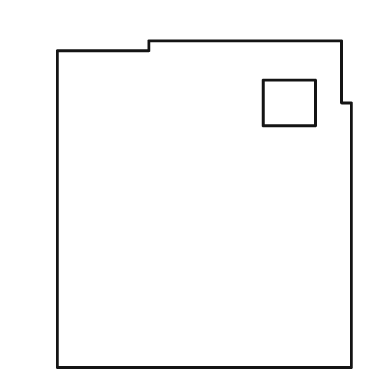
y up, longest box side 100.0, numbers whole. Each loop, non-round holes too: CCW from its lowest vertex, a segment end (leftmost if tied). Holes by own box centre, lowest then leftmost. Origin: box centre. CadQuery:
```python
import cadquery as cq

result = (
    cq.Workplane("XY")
    .moveTo(-45.0, -50.0)
    .lineTo(45.0, -50.0)
    .lineTo(45.0, 31.0)
    .lineTo(42.0, 31.0)
    .lineTo(42.0, 50.0)
    .lineTo(-17.0, 50.0)
    .lineTo(-17.0, 47.0)
    .lineTo(-45.0, 47.0)
    .close()
    .moveTo(18.0, 24.0)
    .lineTo(34.0, 24.0)
    .lineTo(34.0, 38.0)
    .lineTo(18.0, 38.0)
    .close()
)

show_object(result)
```